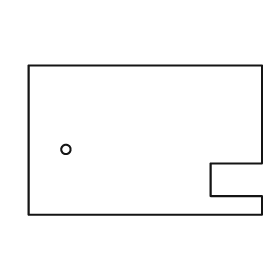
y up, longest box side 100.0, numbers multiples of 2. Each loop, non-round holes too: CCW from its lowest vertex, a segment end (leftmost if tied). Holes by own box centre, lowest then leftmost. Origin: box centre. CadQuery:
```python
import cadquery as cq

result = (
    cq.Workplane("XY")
    .moveTo(-50.0, -32.0)
    .lineTo(50.0, -32.0)
    .lineTo(50.0, -24.0)
    .lineTo(28.0, -24.0)
    .lineTo(28.0, -10.0)
    .lineTo(50.0, -10.0)
    .lineTo(50.0, 32.0)
    .lineTo(-50.0, 32.0)
    .close()
    .moveTo(-34.0, -4.0)
    .circle(2.0)
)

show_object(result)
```